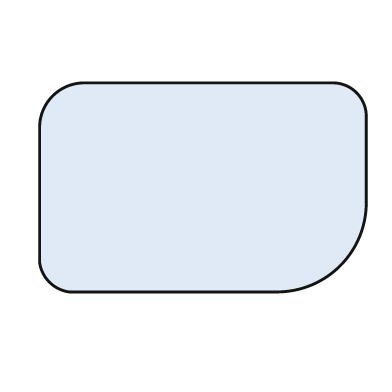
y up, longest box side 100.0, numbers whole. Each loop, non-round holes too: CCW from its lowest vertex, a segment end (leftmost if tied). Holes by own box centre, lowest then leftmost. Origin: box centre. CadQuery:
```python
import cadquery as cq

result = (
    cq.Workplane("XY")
    .moveTo(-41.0, -32.0)
    .lineTo(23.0, -32.0)
    .threePointArc((42.0, -24.0), (50.0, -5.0))
    .lineTo(50.0, 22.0)
    .threePointArc((47.0, 29.0), (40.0, 32.0))
    .lineTo(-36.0, 32.0)
    .threePointArc((-46.0, 28.0), (-50.0, 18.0))
    .lineTo(-50.0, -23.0)
    .threePointArc((-47.0, -29.0), (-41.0, -32.0))
    .close()
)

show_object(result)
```